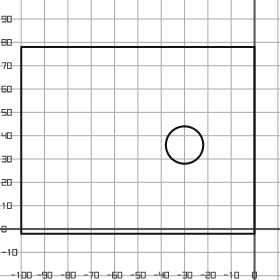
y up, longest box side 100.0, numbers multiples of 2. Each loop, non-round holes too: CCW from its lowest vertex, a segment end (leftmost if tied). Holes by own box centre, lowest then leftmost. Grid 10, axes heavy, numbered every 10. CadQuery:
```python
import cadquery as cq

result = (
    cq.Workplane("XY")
    .moveTo(-100.0, -2.0)
    .lineTo(0.0, -2.0)
    .lineTo(0.0, 78.0)
    .lineTo(-100.0, 78.0)
    .close()
    .moveTo(-30.0, 36.0)
    .circle(8.0)
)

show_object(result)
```